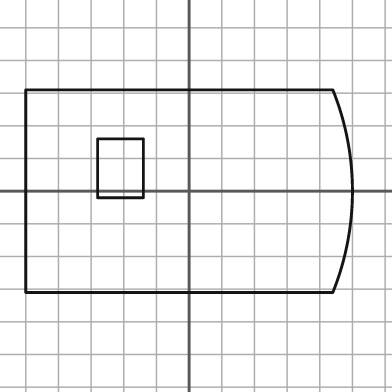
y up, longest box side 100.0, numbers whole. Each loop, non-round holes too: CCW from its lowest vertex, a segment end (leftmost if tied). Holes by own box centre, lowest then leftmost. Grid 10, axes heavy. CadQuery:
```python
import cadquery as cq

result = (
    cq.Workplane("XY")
    .moveTo(-50.0, -31.0)
    .lineTo(44.0, -31.0)
    .threePointArc((50.0, 0.0), (44.0, 31.0))
    .lineTo(-50.0, 31.0)
    .close()
    .moveTo(-28.0, -2.0)
    .lineTo(-14.0, -2.0)
    .lineTo(-14.0, 16.0)
    .lineTo(-28.0, 16.0)
    .close()
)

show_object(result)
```